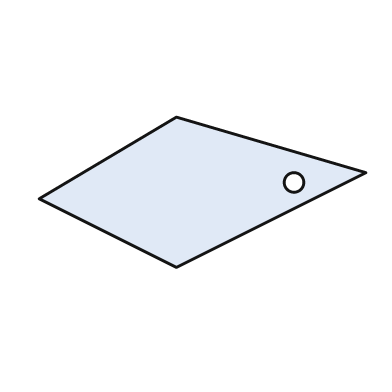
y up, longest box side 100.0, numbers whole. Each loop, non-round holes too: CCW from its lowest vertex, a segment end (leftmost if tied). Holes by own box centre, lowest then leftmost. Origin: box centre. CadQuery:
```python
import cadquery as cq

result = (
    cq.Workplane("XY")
    .moveTo(-8.0, -23.0)
    .lineTo(50.0, 6.0)
    .lineTo(-8.0, 23.0)
    .lineTo(-50.0, -2.0)
    .close()
    .moveTo(28.0, 3.0)
    .circle(3.0)
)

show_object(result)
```